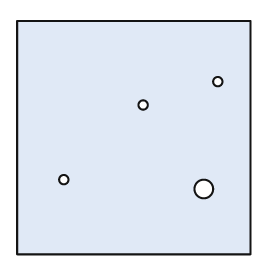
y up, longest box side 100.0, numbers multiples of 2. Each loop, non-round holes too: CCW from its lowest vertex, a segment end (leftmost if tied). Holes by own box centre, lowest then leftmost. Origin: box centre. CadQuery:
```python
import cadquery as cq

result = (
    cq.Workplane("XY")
    .moveTo(-50.0, -50.0)
    .lineTo(50.0, -50.0)
    .lineTo(50.0, 50.0)
    .lineTo(-50.0, 50.0)
    .close()
    .moveTo(30.0, -22.0)
    .circle(4.0)
    .moveTo(-30.0, -18.0)
    .circle(2.0)
    .moveTo(4.0, 14.0)
    .circle(2.0)
    .moveTo(36.0, 24.0)
    .circle(2.0)
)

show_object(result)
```